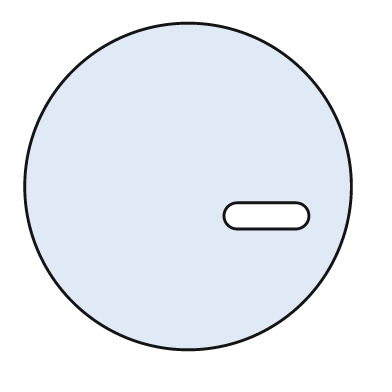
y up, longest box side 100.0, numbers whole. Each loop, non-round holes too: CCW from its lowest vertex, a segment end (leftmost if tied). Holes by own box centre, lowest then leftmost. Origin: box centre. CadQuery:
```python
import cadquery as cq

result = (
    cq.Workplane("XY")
    .moveTo(0.0, 0.0)
    .circle(50.0)
    .moveTo(15.0, -13.0)
    .lineTo(33.0, -13.0)
    .threePointArc((37.0, -9.0), (33.0, -5.0))
    .lineTo(15.0, -5.0)
    .threePointArc((11.0, -9.0), (15.0, -13.0))
    .close()
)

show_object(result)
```